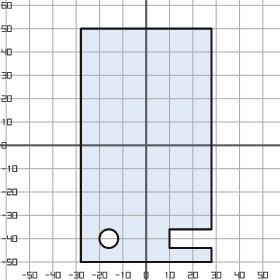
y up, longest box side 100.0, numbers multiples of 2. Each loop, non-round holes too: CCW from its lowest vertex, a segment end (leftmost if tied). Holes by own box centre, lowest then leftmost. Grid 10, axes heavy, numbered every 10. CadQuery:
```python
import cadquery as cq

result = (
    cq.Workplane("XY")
    .moveTo(-28.0, -50.0)
    .lineTo(28.0, -50.0)
    .lineTo(28.0, -44.0)
    .lineTo(10.0, -44.0)
    .lineTo(10.0, -36.0)
    .lineTo(28.0, -36.0)
    .lineTo(28.0, 50.0)
    .lineTo(-28.0, 50.0)
    .close()
    .moveTo(-16.0, -40.0)
    .circle(4.0)
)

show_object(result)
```